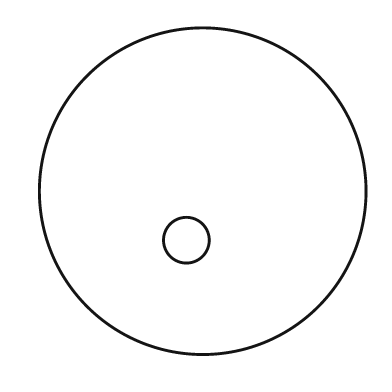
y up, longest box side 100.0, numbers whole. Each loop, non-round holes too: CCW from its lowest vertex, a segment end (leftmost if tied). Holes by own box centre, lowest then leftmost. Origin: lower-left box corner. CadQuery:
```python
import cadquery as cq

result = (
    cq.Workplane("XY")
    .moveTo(50.0, 50.0)
    .circle(50.0)
    .moveTo(45.0, 35.0)
    .circle(7.0)
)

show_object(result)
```